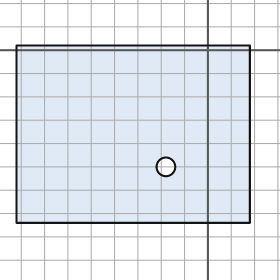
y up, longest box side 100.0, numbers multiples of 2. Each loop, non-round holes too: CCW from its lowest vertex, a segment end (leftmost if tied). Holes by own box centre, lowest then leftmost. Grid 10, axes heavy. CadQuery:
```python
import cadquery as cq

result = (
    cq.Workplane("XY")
    .moveTo(-82.0, -74.0)
    .lineTo(18.0, -74.0)
    .lineTo(18.0, 2.0)
    .lineTo(-82.0, 2.0)
    .close()
    .moveTo(-18.0, -50.0)
    .circle(4.0)
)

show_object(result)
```